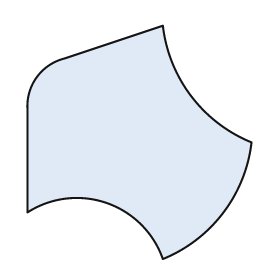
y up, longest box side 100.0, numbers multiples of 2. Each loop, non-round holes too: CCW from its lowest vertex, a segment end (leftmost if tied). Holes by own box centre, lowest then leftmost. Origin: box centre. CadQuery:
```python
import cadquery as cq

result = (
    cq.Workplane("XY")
    .moveTo(10.0, -50.0)
    .threePointArc((36.0, -30.0), (48.0, 0.0))
    .threePointArc((22.0, 20.0), (10.0, 50.0))
    .lineTo(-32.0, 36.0)
    .threePointArc((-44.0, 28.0), (-48.0, 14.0))
    .lineTo(-48.0, -30.0)
    .threePointArc((-14.0, -26.0), (10.0, -50.0))
    .close()
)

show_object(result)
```